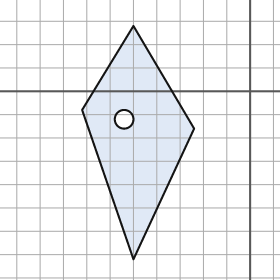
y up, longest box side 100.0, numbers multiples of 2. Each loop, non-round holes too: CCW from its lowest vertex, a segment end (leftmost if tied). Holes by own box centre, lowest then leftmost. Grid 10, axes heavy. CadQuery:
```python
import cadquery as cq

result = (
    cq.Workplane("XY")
    .moveTo(-50.0, -72.0)
    .lineTo(-24.0, -16.0)
    .lineTo(-50.0, 28.0)
    .lineTo(-72.0, -8.0)
    .close()
    .moveTo(-54.0, -12.0)
    .circle(4.0)
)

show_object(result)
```